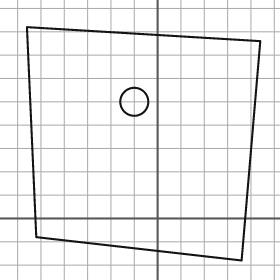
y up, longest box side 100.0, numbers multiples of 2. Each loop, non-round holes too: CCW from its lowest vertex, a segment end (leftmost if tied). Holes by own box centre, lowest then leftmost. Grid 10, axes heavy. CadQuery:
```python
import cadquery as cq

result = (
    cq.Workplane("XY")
    .moveTo(36.0, -18.0)
    .lineTo(44.0, 76.0)
    .lineTo(-56.0, 82.0)
    .lineTo(-52.0, -8.0)
    .close()
    .moveTo(-10.0, 50.0)
    .circle(6.0)
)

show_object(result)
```